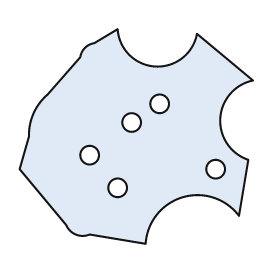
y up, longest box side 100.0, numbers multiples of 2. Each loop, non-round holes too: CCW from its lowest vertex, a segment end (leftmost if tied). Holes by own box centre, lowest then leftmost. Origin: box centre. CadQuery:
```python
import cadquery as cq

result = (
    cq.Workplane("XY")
    .moveTo(4.0, -46.0)
    .threePointArc((20.0, -26.0), (44.0, -34.0))
    .lineTo(48.0, -10.0)
    .threePointArc((36.0, 8.0), (50.0, 24.0))
    .lineTo(26.0, 44.0)
    .threePointArc((8.0, 30.0), (-8.0, 46.0))
    .lineTo(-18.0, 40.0)
    .threePointArc((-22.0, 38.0), (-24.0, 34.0))
    .lineTo(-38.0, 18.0)
    .threePointArc((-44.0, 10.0), (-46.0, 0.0))
    .lineTo(-50.0, -14.0)
    .lineTo(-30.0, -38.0)
    .threePointArc((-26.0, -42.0), (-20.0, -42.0))
    .close()
    .moveTo(-8.0, -22.0)
    .circle(4.0)
    .moveTo(34.0, -14.0)
    .circle(4.0)
    .moveTo(-20.0, -8.0)
    .circle(4.0)
    .moveTo(-2.0, 6.0)
    .circle(4.0)
    .moveTo(10.0, 14.0)
    .circle(4.0)
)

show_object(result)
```